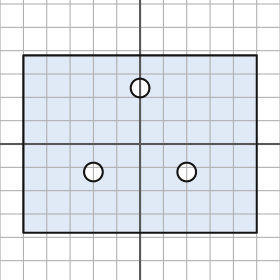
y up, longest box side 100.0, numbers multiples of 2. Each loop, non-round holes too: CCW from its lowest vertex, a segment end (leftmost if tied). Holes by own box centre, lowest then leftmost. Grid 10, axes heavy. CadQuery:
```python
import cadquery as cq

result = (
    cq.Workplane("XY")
    .moveTo(-50.0, -38.0)
    .lineTo(50.0, -38.0)
    .lineTo(50.0, 38.0)
    .lineTo(-50.0, 38.0)
    .close()
    .moveTo(-20.0, -12.0)
    .circle(4.0)
    .moveTo(20.0, -12.0)
    .circle(4.0)
    .moveTo(0.0, 24.0)
    .circle(4.0)
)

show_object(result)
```